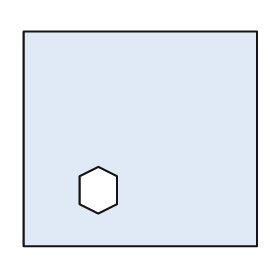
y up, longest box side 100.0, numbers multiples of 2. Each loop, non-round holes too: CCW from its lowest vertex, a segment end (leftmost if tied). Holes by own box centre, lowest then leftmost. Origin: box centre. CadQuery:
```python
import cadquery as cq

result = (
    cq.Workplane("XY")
    .moveTo(-50.0, -46.0)
    .lineTo(50.0, -46.0)
    .lineTo(50.0, 46.0)
    .lineTo(-50.0, 46.0)
    .close()
    .moveTo(-18.0, -32.0)
    .lineTo(-10.0, -28.0)
    .lineTo(-10.0, -16.0)
    .lineTo(-18.0, -12.0)
    .lineTo(-26.0, -16.0)
    .lineTo(-26.0, -28.0)
    .close()
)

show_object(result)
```